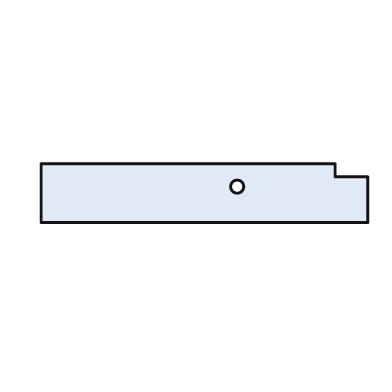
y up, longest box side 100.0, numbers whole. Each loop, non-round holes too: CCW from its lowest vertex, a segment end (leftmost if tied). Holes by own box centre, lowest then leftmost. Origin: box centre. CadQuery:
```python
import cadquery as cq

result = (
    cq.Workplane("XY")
    .moveTo(-50.0, -9.0)
    .lineTo(50.0, -9.0)
    .lineTo(50.0, 5.0)
    .lineTo(40.0, 5.0)
    .lineTo(40.0, 9.0)
    .lineTo(-50.0, 9.0)
    .close()
    .moveTo(10.0, 2.0)
    .circle(2.0)
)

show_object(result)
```